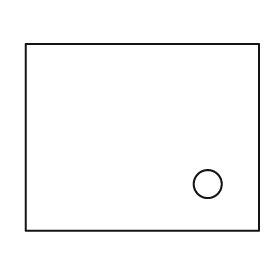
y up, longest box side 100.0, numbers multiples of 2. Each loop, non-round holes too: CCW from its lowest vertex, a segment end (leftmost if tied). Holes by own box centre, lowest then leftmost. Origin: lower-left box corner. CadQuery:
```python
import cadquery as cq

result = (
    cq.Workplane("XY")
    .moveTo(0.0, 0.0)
    .lineTo(100.0, 0.0)
    .lineTo(100.0, 80.0)
    .lineTo(0.0, 80.0)
    .close()
    .moveTo(78.0, 20.0)
    .circle(6.0)
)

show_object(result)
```